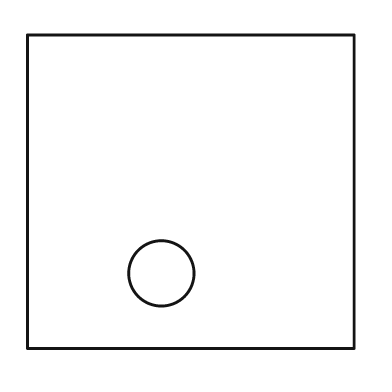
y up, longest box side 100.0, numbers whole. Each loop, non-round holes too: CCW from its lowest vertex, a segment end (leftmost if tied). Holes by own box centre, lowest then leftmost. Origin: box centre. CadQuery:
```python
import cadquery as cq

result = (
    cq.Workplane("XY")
    .moveTo(-50.0, -48.0)
    .lineTo(50.0, -48.0)
    .lineTo(50.0, 48.0)
    .lineTo(-50.0, 48.0)
    .close()
    .moveTo(-9.0, -25.0)
    .circle(10.0)
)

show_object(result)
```